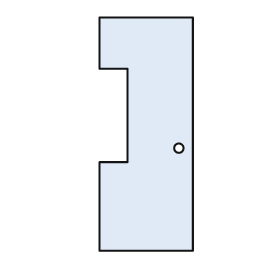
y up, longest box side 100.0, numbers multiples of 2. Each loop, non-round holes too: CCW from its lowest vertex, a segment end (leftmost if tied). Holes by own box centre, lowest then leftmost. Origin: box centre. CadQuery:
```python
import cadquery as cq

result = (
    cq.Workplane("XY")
    .moveTo(-20.0, -50.0)
    .lineTo(20.0, -50.0)
    .lineTo(20.0, 50.0)
    .lineTo(-20.0, 50.0)
    .lineTo(-20.0, 28.0)
    .lineTo(-8.0, 28.0)
    .lineTo(-8.0, -12.0)
    .lineTo(-20.0, -12.0)
    .close()
    .moveTo(14.0, -6.0)
    .circle(2.0)
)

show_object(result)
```